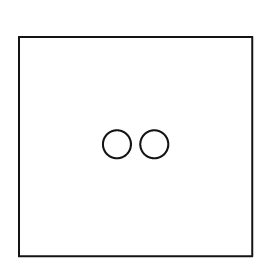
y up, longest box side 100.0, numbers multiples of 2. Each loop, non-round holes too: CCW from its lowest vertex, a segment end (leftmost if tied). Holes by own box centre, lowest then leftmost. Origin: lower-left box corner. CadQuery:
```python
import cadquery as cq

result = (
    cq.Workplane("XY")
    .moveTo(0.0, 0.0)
    .lineTo(100.0, 0.0)
    .lineTo(100.0, 94.0)
    .lineTo(0.0, 94.0)
    .close()
    .moveTo(42.0, 48.0)
    .circle(6.0)
    .moveTo(58.0, 48.0)
    .circle(6.0)
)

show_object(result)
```